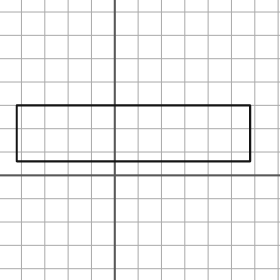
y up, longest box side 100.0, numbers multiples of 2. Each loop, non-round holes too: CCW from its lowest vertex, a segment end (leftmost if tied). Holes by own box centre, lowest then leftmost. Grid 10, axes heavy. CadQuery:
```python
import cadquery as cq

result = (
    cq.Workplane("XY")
    .moveTo(-42.0, 6.0)
    .lineTo(58.0, 6.0)
    .lineTo(58.0, 30.0)
    .lineTo(-42.0, 30.0)
    .close()
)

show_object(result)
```